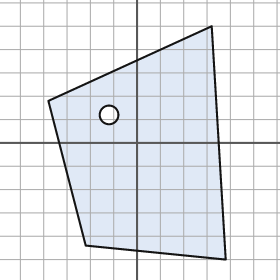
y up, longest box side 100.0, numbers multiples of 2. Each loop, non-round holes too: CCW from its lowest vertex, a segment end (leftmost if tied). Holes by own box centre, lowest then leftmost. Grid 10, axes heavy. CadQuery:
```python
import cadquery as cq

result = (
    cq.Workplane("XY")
    .moveTo(38.0, -50.0)
    .lineTo(32.0, 50.0)
    .lineTo(-38.0, 18.0)
    .lineTo(-22.0, -44.0)
    .close()
    .moveTo(-12.0, 12.0)
    .circle(4.0)
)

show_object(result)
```